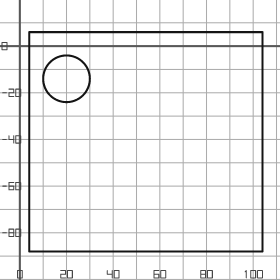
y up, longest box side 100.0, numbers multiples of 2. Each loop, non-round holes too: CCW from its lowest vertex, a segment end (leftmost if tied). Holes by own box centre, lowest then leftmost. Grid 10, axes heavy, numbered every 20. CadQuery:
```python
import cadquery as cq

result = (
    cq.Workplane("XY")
    .moveTo(4.0, -88.0)
    .lineTo(104.0, -88.0)
    .lineTo(104.0, 6.0)
    .lineTo(4.0, 6.0)
    .close()
    .moveTo(20.0, -14.0)
    .circle(10.0)
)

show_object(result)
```